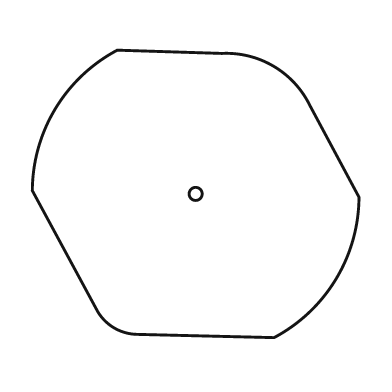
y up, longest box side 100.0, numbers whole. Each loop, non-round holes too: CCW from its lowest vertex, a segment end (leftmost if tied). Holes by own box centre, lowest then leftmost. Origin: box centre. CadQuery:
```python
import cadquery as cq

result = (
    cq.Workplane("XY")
    .moveTo(24.0, -44.0)
    .threePointArc((43.0, -26.0), (50.0, -1.0))
    .lineTo(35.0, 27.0)
    .threePointArc((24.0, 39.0), (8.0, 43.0))
    .lineTo(-24.0, 44.0)
    .threePointArc((-43.0, 26.0), (-50.0, 1.0))
    .lineTo(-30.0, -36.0)
    .threePointArc((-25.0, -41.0), (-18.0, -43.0))
    .close()
    .moveTo(0.0, 0.0)
    .circle(2.0)
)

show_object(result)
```